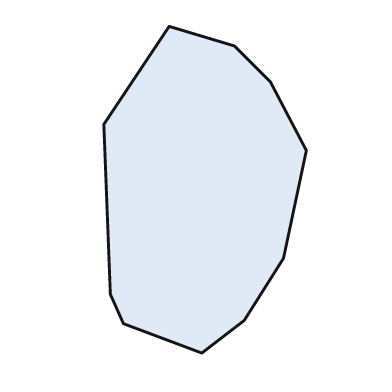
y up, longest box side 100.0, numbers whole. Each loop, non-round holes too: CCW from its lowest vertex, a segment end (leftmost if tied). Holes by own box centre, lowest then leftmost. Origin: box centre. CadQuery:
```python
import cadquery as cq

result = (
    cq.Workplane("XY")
    .moveTo(-1.0, -50.0)
    .lineTo(12.0, -40.0)
    .lineTo(24.0, -21.0)
    .lineTo(31.0, 12.0)
    .lineTo(20.0, 33.0)
    .lineTo(9.0, 44.0)
    .lineTo(-11.0, 50.0)
    .lineTo(-31.0, 20.0)
    .lineTo(-29.0, -32.0)
    .lineTo(-25.0, -41.0)
    .close()
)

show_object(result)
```